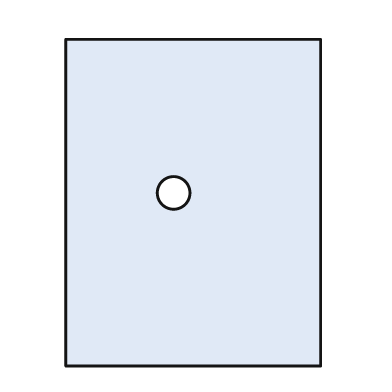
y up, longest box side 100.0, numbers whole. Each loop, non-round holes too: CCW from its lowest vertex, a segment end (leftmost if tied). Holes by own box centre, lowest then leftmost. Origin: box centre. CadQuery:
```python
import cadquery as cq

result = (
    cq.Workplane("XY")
    .moveTo(-39.0, -50.0)
    .lineTo(39.0, -50.0)
    .lineTo(39.0, 50.0)
    .lineTo(-39.0, 50.0)
    .close()
    .moveTo(-6.0, 3.0)
    .circle(5.0)
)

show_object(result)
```